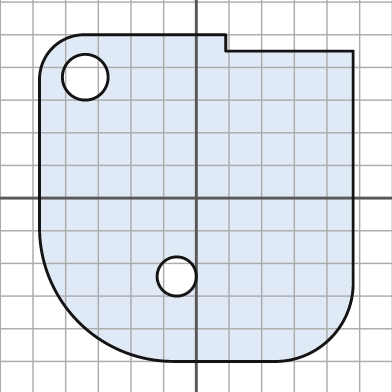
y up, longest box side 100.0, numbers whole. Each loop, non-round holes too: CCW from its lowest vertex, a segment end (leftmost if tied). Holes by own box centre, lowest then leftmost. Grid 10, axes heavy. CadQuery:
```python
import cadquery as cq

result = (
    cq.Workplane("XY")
    .moveTo(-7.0, -50.0)
    .lineTo(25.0, -50.0)
    .threePointArc((41.0, -43.0), (48.0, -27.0))
    .lineTo(48.0, 45.0)
    .lineTo(9.0, 45.0)
    .lineTo(9.0, 50.0)
    .lineTo(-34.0, 50.0)
    .threePointArc((-44.0, 46.0), (-48.0, 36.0))
    .lineTo(-48.0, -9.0)
    .threePointArc((-36.0, -38.0), (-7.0, -50.0))
    .close()
    .moveTo(-6.0, -24.0)
    .circle(6.0)
    .moveTo(-34.0, 37.0)
    .circle(7.0)
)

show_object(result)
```